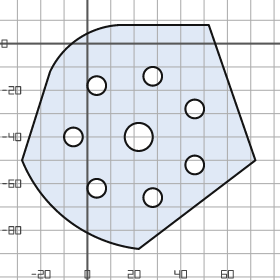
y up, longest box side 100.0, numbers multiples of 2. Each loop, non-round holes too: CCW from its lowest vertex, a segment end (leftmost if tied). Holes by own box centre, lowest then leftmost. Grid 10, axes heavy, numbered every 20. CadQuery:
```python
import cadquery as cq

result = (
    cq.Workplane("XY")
    .moveTo(22.0, -88.0)
    .lineTo(72.0, -50.0)
    .lineTo(52.0, 8.0)
    .lineTo(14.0, 8.0)
    .threePointArc((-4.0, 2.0), (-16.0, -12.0))
    .lineTo(-28.0, -50.0)
    .threePointArc((-8.0, -76.0), (22.0, -88.0))
    .close()
    .moveTo(28.0, -66.0)
    .circle(4.0)
    .moveTo(4.0, -62.0)
    .circle(4.0)
    .moveTo(46.0, -52.0)
    .circle(4.0)
    .moveTo(-6.0, -40.0)
    .circle(4.0)
    .moveTo(22.0, -40.0)
    .circle(6.0)
    .moveTo(46.0, -28.0)
    .circle(4.0)
    .moveTo(4.0, -18.0)
    .circle(4.0)
    .moveTo(28.0, -14.0)
    .circle(4.0)
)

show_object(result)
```